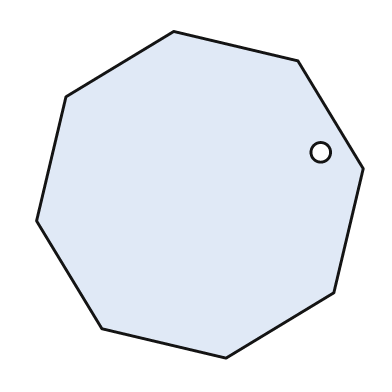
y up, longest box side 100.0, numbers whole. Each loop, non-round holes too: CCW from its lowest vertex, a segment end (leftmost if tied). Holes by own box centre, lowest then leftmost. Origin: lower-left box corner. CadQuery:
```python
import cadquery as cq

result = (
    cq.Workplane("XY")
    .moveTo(58.0, 0.0)
    .lineTo(91.0, 20.0)
    .lineTo(100.0, 58.0)
    .lineTo(80.0, 91.0)
    .lineTo(42.0, 100.0)
    .lineTo(9.0, 80.0)
    .lineTo(0.0, 42.0)
    .lineTo(20.0, 9.0)
    .close()
    .moveTo(87.0, 63.0)
    .circle(3.0)
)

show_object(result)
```